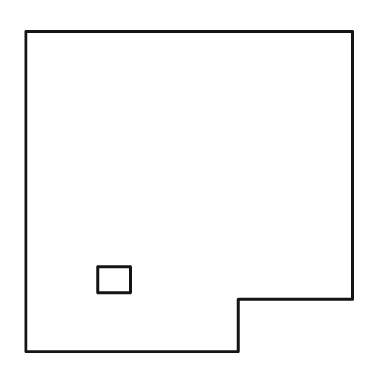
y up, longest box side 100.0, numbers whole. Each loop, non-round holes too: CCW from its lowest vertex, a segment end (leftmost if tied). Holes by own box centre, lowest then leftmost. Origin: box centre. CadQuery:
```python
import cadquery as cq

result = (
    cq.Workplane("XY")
    .moveTo(-50.0, -49.0)
    .lineTo(15.0, -49.0)
    .lineTo(15.0, -33.0)
    .lineTo(50.0, -33.0)
    .lineTo(50.0, 49.0)
    .lineTo(-50.0, 49.0)
    .close()
    .moveTo(-28.0, -31.0)
    .lineTo(-18.0, -31.0)
    .lineTo(-18.0, -23.0)
    .lineTo(-28.0, -23.0)
    .close()
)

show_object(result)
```